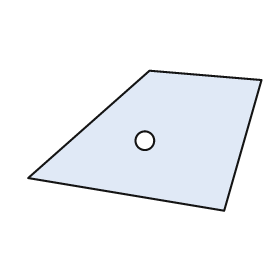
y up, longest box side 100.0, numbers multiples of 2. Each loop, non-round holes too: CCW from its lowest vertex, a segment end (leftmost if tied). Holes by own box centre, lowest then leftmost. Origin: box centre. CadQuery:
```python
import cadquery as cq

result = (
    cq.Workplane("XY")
    .moveTo(34.0, -30.0)
    .lineTo(50.0, 26.0)
    .lineTo(2.0, 30.0)
    .lineTo(-50.0, -16.0)
    .close()
    .moveTo(0.0, 0.0)
    .circle(4.0)
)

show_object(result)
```